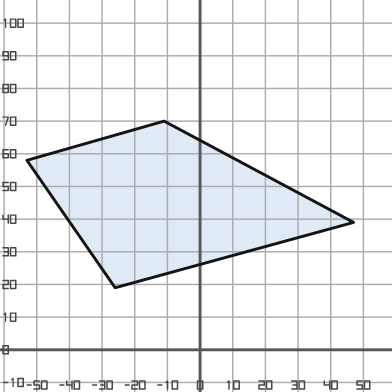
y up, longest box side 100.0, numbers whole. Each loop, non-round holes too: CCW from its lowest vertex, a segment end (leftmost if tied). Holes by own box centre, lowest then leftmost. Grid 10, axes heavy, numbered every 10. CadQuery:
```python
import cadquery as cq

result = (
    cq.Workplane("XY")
    .moveTo(-26.0, 19.0)
    .lineTo(47.0, 39.0)
    .lineTo(-11.0, 70.0)
    .lineTo(-53.0, 58.0)
    .close()
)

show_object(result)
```